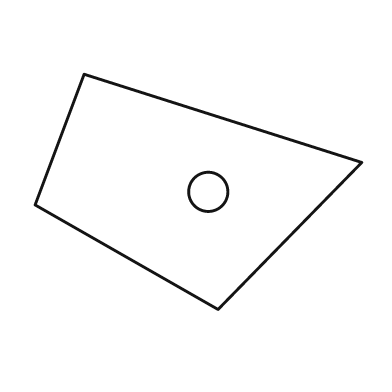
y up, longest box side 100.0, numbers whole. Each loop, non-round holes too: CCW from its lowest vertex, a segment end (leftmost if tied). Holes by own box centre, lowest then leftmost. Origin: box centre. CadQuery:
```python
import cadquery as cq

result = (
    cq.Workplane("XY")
    .moveTo(6.0, -36.0)
    .lineTo(50.0, 9.0)
    .lineTo(-35.0, 36.0)
    .lineTo(-50.0, -4.0)
    .close()
    .moveTo(3.0, 0.0)
    .circle(6.0)
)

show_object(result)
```